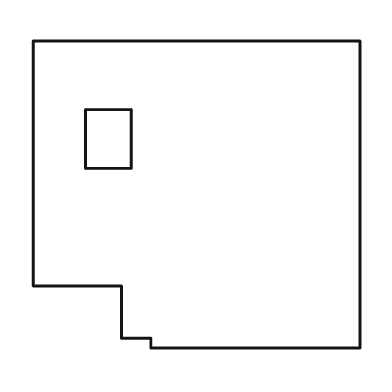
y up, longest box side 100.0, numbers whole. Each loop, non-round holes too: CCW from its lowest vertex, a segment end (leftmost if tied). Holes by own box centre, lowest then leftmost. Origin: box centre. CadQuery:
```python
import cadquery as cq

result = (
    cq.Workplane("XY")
    .moveTo(-14.0, -47.0)
    .lineTo(50.0, -47.0)
    .lineTo(50.0, 47.0)
    .lineTo(-50.0, 47.0)
    .lineTo(-50.0, -28.0)
    .lineTo(-23.0, -28.0)
    .lineTo(-23.0, -44.0)
    .lineTo(-14.0, -44.0)
    .close()
    .moveTo(-34.0, 8.0)
    .lineTo(-20.0, 8.0)
    .lineTo(-20.0, 26.0)
    .lineTo(-34.0, 26.0)
    .close()
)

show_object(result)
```